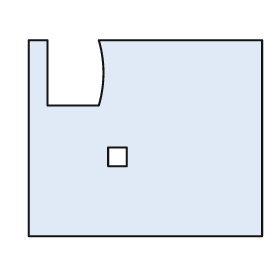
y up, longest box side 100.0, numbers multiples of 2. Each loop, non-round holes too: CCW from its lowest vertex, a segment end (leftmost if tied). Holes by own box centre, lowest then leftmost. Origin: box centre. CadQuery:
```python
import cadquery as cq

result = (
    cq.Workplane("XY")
    .moveTo(-50.0, -42.0)
    .lineTo(50.0, -42.0)
    .lineTo(50.0, 42.0)
    .lineTo(-20.0, 42.0)
    .threePointArc((-18.0, 28.0), (-20.0, 14.0))
    .lineTo(-42.0, 14.0)
    .lineTo(-42.0, 42.0)
    .lineTo(-50.0, 42.0)
    .close()
    .moveTo(-16.0, -12.0)
    .lineTo(-8.0, -12.0)
    .lineTo(-8.0, -4.0)
    .lineTo(-16.0, -4.0)
    .close()
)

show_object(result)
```